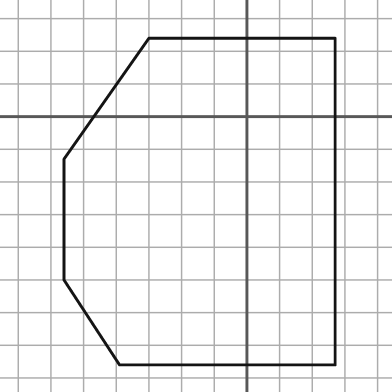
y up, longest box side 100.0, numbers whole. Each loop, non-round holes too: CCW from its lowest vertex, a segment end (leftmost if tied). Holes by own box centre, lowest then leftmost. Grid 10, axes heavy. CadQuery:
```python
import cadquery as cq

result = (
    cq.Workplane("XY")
    .moveTo(-39.0, -76.0)
    .lineTo(27.0, -76.0)
    .lineTo(27.0, 24.0)
    .lineTo(-30.0, 24.0)
    .lineTo(-56.0, -13.0)
    .lineTo(-56.0, -50.0)
    .close()
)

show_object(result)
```